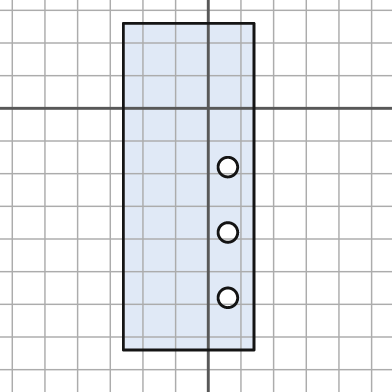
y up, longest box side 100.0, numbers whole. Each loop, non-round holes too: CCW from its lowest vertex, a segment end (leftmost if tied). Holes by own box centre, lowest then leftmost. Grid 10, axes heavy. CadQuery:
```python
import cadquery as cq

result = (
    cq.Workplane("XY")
    .moveTo(-26.0, -74.0)
    .lineTo(14.0, -74.0)
    .lineTo(14.0, 26.0)
    .lineTo(-26.0, 26.0)
    .close()
    .moveTo(6.0, -58.0)
    .circle(3.0)
    .moveTo(6.0, -38.0)
    .circle(3.0)
    .moveTo(6.0, -18.0)
    .circle(3.0)
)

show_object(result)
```